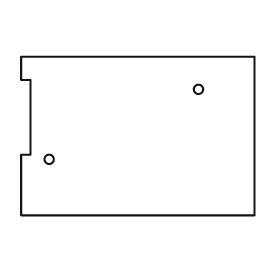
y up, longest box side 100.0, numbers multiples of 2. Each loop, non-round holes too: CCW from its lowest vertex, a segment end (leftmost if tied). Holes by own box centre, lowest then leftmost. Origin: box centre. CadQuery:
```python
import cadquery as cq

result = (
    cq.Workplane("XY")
    .moveTo(-50.0, -34.0)
    .lineTo(50.0, -34.0)
    .lineTo(50.0, 34.0)
    .lineTo(-50.0, 34.0)
    .lineTo(-50.0, 24.0)
    .lineTo(-46.0, 24.0)
    .lineTo(-46.0, -8.0)
    .lineTo(-50.0, -8.0)
    .close()
    .moveTo(-38.0, -10.0)
    .circle(2.0)
    .moveTo(26.0, 20.0)
    .circle(2.0)
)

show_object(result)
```